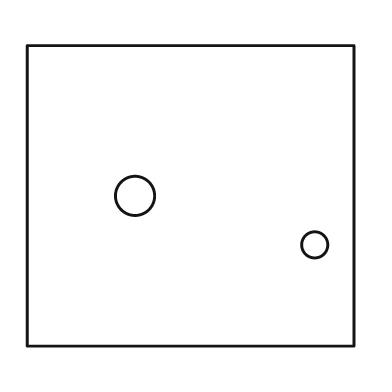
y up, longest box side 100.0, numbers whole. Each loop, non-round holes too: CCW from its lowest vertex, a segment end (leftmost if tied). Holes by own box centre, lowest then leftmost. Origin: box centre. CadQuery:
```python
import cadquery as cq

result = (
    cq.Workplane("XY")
    .moveTo(-50.0, -46.0)
    .lineTo(50.0, -46.0)
    .lineTo(50.0, 46.0)
    .lineTo(-50.0, 46.0)
    .close()
    .moveTo(38.0, -15.0)
    .circle(4.0)
    .moveTo(-17.0, 0.0)
    .circle(6.0)
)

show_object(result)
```